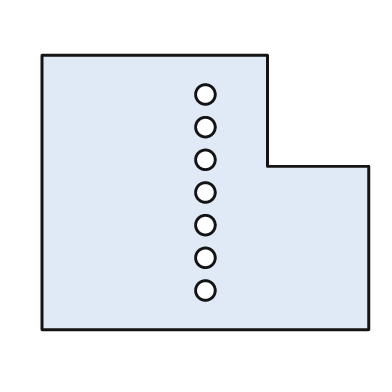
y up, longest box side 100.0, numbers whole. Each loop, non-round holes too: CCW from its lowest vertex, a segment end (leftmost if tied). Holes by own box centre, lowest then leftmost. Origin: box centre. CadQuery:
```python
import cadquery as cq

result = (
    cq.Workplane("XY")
    .moveTo(-50.0, -42.0)
    .lineTo(50.0, -42.0)
    .lineTo(50.0, 8.0)
    .lineTo(19.0, 8.0)
    .lineTo(19.0, 42.0)
    .lineTo(-50.0, 42.0)
    .close()
    .moveTo(0.0, -30.0)
    .circle(3.0)
    .moveTo(0.0, -20.0)
    .circle(3.0)
    .moveTo(0.0, -10.0)
    .circle(3.0)
    .moveTo(0.0, 0.0)
    .circle(3.0)
    .moveTo(0.0, 10.0)
    .circle(3.0)
    .moveTo(0.0, 20.0)
    .circle(3.0)
    .moveTo(0.0, 30.0)
    .circle(3.0)
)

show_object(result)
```